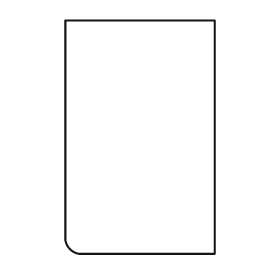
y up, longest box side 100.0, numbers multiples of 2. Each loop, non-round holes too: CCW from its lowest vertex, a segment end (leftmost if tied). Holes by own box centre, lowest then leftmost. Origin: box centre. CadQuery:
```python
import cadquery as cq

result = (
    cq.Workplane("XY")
    .moveTo(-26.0, -50.0)
    .lineTo(32.0, -50.0)
    .lineTo(32.0, 50.0)
    .lineTo(-32.0, 50.0)
    .lineTo(-32.0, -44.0)
    .threePointArc((-30.0, -48.0), (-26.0, -50.0))
    .close()
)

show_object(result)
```